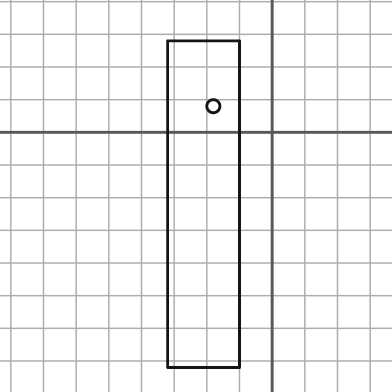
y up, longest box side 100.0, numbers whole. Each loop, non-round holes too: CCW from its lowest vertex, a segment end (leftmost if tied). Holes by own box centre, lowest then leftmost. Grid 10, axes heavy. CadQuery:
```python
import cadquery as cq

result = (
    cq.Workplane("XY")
    .moveTo(-32.0, -72.0)
    .lineTo(-10.0, -72.0)
    .lineTo(-10.0, 28.0)
    .lineTo(-32.0, 28.0)
    .close()
    .moveTo(-18.0, 8.0)
    .circle(2.0)
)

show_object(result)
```